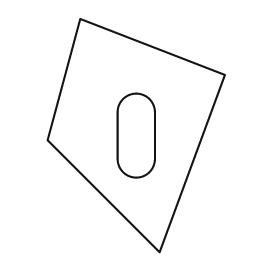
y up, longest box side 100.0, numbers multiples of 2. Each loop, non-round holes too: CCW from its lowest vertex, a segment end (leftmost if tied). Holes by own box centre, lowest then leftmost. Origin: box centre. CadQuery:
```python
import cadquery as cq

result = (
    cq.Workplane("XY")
    .moveTo(10.0, -50.0)
    .lineTo(38.0, 26.0)
    .lineTo(-24.0, 50.0)
    .lineTo(-38.0, -2.0)
    .close()
    .moveTo(-8.0, -10.0)
    .threePointArc((0.0, -18.0), (8.0, -10.0))
    .lineTo(8.0, 10.0)
    .threePointArc((0.0, 18.0), (-8.0, 10.0))
    .close()
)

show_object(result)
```